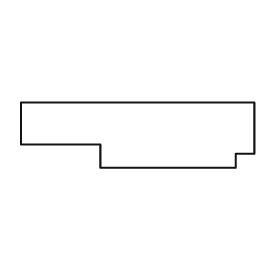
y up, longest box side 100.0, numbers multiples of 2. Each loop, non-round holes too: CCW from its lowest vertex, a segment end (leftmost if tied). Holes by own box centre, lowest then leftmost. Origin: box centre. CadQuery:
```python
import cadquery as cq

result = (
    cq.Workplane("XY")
    .moveTo(-16.0, -14.0)
    .lineTo(42.0, -14.0)
    .lineTo(42.0, -8.0)
    .lineTo(50.0, -8.0)
    .lineTo(50.0, 14.0)
    .lineTo(-50.0, 14.0)
    .lineTo(-50.0, -4.0)
    .lineTo(-16.0, -4.0)
    .close()
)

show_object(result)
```